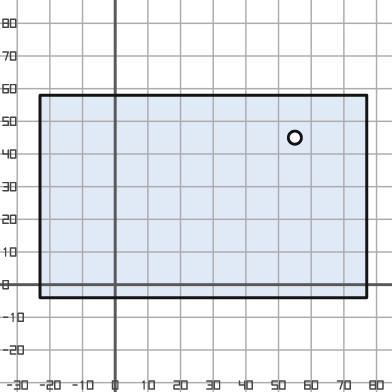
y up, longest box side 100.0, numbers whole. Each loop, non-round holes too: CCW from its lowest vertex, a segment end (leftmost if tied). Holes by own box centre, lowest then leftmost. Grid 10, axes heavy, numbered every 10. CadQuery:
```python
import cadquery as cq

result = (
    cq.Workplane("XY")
    .moveTo(-23.0, -4.0)
    .lineTo(77.0, -4.0)
    .lineTo(77.0, 58.0)
    .lineTo(-23.0, 58.0)
    .close()
    .moveTo(55.0, 45.0)
    .circle(2.0)
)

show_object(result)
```